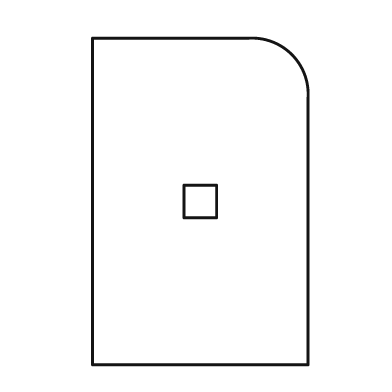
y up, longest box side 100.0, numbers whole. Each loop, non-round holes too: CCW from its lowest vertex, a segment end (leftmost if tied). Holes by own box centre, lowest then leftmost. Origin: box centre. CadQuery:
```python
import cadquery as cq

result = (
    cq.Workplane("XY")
    .moveTo(-33.0, -50.0)
    .lineTo(33.0, -50.0)
    .lineTo(33.0, 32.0)
    .threePointArc((28.0, 45.0), (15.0, 50.0))
    .lineTo(-33.0, 50.0)
    .close()
    .moveTo(-5.0, -5.0)
    .lineTo(5.0, -5.0)
    .lineTo(5.0, 5.0)
    .lineTo(-5.0, 5.0)
    .close()
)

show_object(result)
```